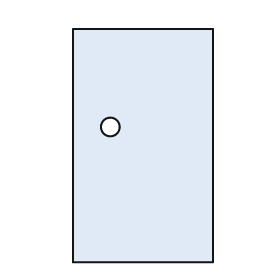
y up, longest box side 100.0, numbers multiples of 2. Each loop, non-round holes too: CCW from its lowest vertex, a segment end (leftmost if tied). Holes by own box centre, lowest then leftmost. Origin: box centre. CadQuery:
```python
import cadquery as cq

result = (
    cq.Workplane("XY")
    .moveTo(-30.0, -50.0)
    .lineTo(30.0, -50.0)
    .lineTo(30.0, 50.0)
    .lineTo(-30.0, 50.0)
    .close()
    .moveTo(-14.0, 8.0)
    .circle(4.0)
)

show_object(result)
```